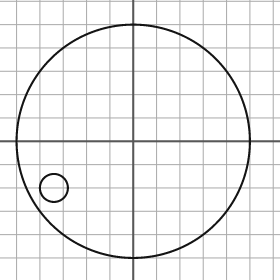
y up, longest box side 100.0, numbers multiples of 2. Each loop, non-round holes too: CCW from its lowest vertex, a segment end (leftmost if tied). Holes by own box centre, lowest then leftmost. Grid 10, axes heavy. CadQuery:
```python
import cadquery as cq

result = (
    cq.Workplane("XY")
    .moveTo(0.0, 0.0)
    .circle(50.0)
    .moveTo(-34.0, -20.0)
    .circle(6.0)
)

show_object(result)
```